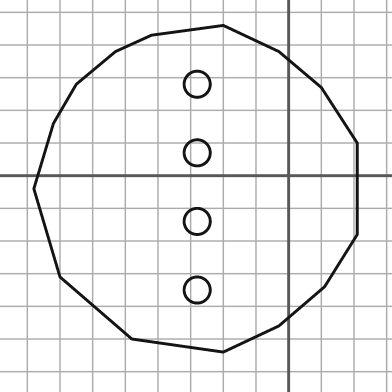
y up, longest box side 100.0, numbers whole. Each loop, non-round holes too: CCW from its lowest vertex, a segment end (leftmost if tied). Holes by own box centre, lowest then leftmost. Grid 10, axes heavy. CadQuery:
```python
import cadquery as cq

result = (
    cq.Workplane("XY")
    .moveTo(-20.0, -54.0)
    .lineTo(-3.0, -46.0)
    .lineTo(11.0, -34.0)
    .lineTo(21.0, -18.0)
    .lineTo(21.0, 10.0)
    .lineTo(10.0, 27.0)
    .lineTo(-3.0, 38.0)
    .lineTo(-20.0, 46.0)
    .lineTo(-42.0, 43.0)
    .lineTo(-53.0, 38.0)
    .lineTo(-65.0, 28.0)
    .lineTo(-72.0, 16.0)
    .lineTo(-78.0, -4.0)
    .lineTo(-70.0, -31.0)
    .lineTo(-48.0, -50.0)
    .close()
    .moveTo(-28.0, -35.0)
    .circle(4.0)
    .moveTo(-28.0, -14.0)
    .circle(4.0)
    .moveTo(-28.0, 7.0)
    .circle(4.0)
    .moveTo(-28.0, 28.0)
    .circle(4.0)
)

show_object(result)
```